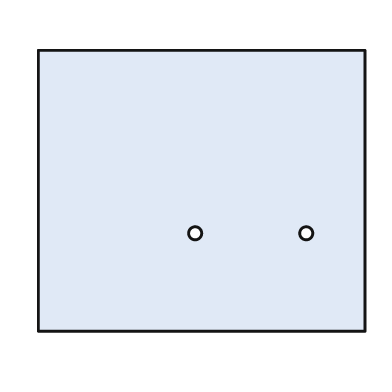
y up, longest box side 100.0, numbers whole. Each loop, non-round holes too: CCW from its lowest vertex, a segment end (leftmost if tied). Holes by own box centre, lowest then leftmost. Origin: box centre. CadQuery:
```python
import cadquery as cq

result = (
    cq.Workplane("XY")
    .moveTo(-50.0, -43.0)
    .lineTo(50.0, -43.0)
    .lineTo(50.0, 43.0)
    .lineTo(-50.0, 43.0)
    .close()
    .moveTo(-2.0, -13.0)
    .circle(2.0)
    .moveTo(32.0, -13.0)
    .circle(2.0)
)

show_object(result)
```